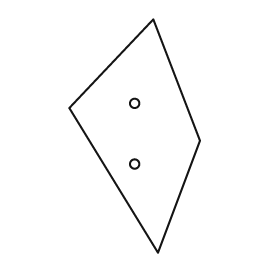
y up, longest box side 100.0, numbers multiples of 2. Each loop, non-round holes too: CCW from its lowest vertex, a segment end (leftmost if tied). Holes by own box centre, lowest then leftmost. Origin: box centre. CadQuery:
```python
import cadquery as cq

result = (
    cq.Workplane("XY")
    .moveTo(10.0, -50.0)
    .lineTo(28.0, -2.0)
    .lineTo(8.0, 50.0)
    .lineTo(-28.0, 12.0)
    .close()
    .moveTo(0.0, -12.0)
    .circle(2.0)
    .moveTo(0.0, 14.0)
    .circle(2.0)
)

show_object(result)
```